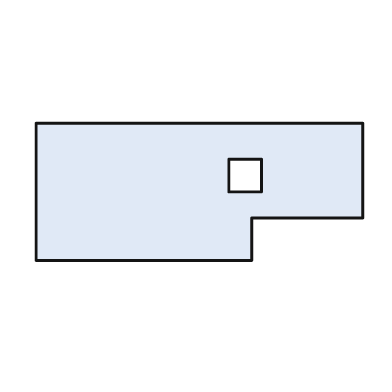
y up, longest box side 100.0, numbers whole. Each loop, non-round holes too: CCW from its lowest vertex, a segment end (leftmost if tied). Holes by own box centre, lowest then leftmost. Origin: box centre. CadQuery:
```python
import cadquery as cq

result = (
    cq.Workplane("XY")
    .moveTo(-50.0, -21.0)
    .lineTo(16.0, -21.0)
    .lineTo(16.0, -8.0)
    .lineTo(50.0, -8.0)
    .lineTo(50.0, 21.0)
    .lineTo(-50.0, 21.0)
    .close()
    .moveTo(9.0, 0.0)
    .lineTo(19.0, 0.0)
    .lineTo(19.0, 10.0)
    .lineTo(9.0, 10.0)
    .close()
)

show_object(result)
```